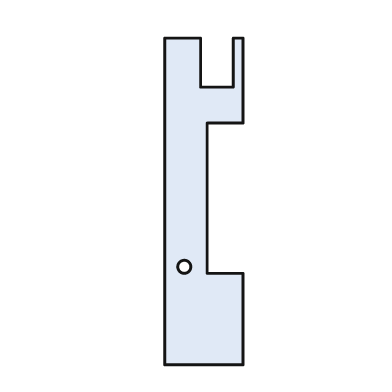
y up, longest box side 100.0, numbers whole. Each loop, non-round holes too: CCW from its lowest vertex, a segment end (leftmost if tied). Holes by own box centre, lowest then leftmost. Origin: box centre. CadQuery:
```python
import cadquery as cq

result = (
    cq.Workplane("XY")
    .moveTo(-12.0, -50.0)
    .lineTo(12.0, -50.0)
    .lineTo(12.0, -22.0)
    .lineTo(1.0, -22.0)
    .lineTo(1.0, 24.0)
    .lineTo(12.0, 24.0)
    .lineTo(12.0, 50.0)
    .lineTo(9.0, 50.0)
    .lineTo(9.0, 35.0)
    .lineTo(-1.0, 35.0)
    .lineTo(-1.0, 50.0)
    .lineTo(-12.0, 50.0)
    .close()
    .moveTo(-6.0, -20.0)
    .circle(2.0)
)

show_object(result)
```